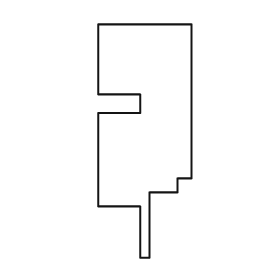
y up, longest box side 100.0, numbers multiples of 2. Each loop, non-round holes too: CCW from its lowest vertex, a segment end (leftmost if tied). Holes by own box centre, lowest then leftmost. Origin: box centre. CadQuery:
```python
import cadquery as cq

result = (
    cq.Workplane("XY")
    .moveTo(-2.0, -50.0)
    .lineTo(2.0, -50.0)
    .lineTo(2.0, -22.0)
    .lineTo(14.0, -22.0)
    .lineTo(14.0, -16.0)
    .lineTo(20.0, -16.0)
    .lineTo(20.0, 50.0)
    .lineTo(-20.0, 50.0)
    .lineTo(-20.0, 20.0)
    .lineTo(-2.0, 20.0)
    .lineTo(-2.0, 12.0)
    .lineTo(-20.0, 12.0)
    .lineTo(-20.0, -28.0)
    .lineTo(-2.0, -28.0)
    .close()
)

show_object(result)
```